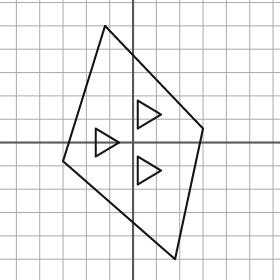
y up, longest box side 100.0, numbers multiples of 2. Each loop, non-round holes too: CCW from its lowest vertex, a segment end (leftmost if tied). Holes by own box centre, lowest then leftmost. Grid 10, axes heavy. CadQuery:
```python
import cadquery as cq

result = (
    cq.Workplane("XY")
    .moveTo(18.0, -50.0)
    .lineTo(30.0, 6.0)
    .lineTo(-12.0, 50.0)
    .lineTo(-30.0, -8.0)
    .close()
    .moveTo(2.0, -18.0)
    .lineTo(12.0, -12.0)
    .lineTo(2.0, -6.0)
    .close()
    .moveTo(-16.0, -6.0)
    .lineTo(-6.0, 0.0)
    .lineTo(-16.0, 6.0)
    .close()
    .moveTo(2.0, 6.0)
    .lineTo(12.0, 12.0)
    .lineTo(2.0, 18.0)
    .close()
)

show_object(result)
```